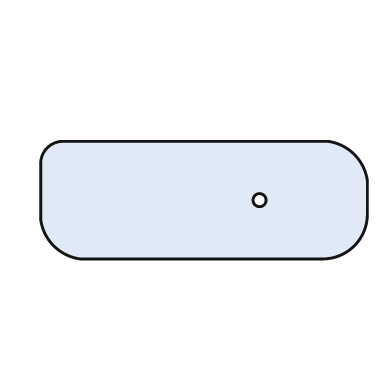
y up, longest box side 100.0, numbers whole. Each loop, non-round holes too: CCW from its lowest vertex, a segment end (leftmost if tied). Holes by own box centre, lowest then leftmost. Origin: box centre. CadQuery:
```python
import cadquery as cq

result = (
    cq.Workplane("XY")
    .moveTo(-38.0, -18.0)
    .lineTo(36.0, -18.0)
    .threePointArc((46.0, -14.0), (50.0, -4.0))
    .lineTo(50.0, 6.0)
    .threePointArc((46.0, 14.0), (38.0, 18.0))
    .lineTo(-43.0, 18.0)
    .threePointArc((-48.0, 16.0), (-50.0, 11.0))
    .lineTo(-50.0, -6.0)
    .threePointArc((-46.0, -14.0), (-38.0, -18.0))
    .close()
    .moveTo(17.0, 0.0)
    .circle(2.0)
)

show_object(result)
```